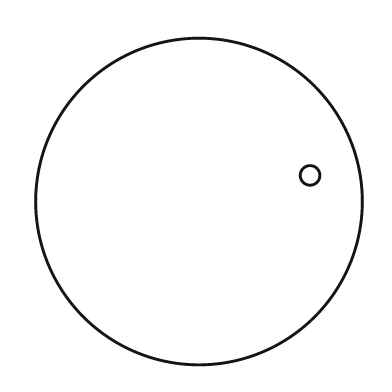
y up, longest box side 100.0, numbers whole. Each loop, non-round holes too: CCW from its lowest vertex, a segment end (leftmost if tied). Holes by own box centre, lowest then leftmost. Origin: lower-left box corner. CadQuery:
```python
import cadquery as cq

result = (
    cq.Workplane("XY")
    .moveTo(50.0, 50.0)
    .circle(50.0)
    .moveTo(84.0, 58.0)
    .circle(3.0)
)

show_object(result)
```